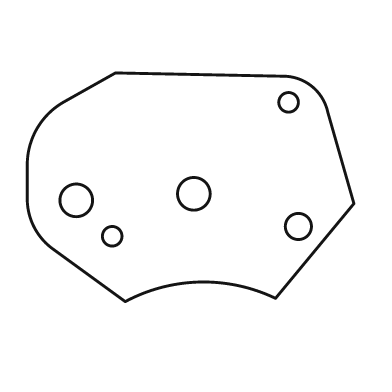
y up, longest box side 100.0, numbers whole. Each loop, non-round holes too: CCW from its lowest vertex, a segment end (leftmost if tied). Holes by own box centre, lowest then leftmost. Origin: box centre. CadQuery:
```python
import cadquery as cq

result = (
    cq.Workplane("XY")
    .moveTo(-20.0, -35.0)
    .threePointArc((3.0, -29.0), (26.0, -34.0))
    .lineTo(50.0, -5.0)
    .lineTo(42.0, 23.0)
    .threePointArc((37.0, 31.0), (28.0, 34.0))
    .lineTo(-23.0, 35.0)
    .lineTo(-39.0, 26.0)
    .threePointArc((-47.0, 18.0), (-50.0, 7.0))
    .lineTo(-50.0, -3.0)
    .threePointArc((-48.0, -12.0), (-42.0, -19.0))
    .close()
    .moveTo(-24.0, -15.0)
    .circle(3.0)
    .moveTo(33.0, -12.0)
    .circle(4.0)
    .moveTo(-35.0, -4.0)
    .circle(5.0)
    .moveTo(1.0, -2.0)
    .circle(5.0)
    .moveTo(30.0, 26.0)
    .circle(3.0)
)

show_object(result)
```